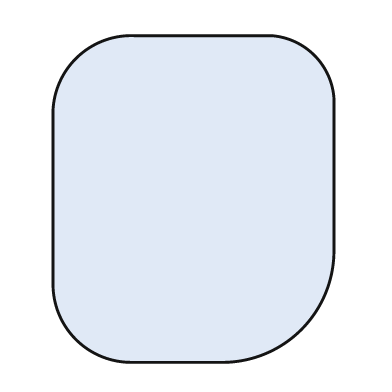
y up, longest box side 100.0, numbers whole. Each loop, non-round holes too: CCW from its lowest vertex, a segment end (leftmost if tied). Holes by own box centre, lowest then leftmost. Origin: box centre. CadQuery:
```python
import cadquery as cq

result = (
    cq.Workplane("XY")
    .moveTo(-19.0, -50.0)
    .lineTo(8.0, -50.0)
    .threePointArc((33.0, -40.0), (43.0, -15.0))
    .lineTo(43.0, 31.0)
    .threePointArc((37.0, 44.0), (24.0, 50.0))
    .lineTo(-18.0, 50.0)
    .threePointArc((-36.0, 43.0), (-43.0, 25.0))
    .lineTo(-43.0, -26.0)
    .threePointArc((-36.0, -43.0), (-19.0, -50.0))
    .close()
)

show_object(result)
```